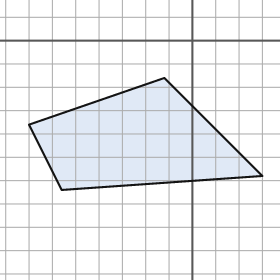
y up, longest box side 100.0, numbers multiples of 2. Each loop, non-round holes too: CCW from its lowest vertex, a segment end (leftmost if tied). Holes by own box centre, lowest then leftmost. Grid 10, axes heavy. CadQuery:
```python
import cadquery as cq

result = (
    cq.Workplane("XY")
    .moveTo(-56.0, -64.0)
    .lineTo(30.0, -58.0)
    .lineTo(-12.0, -16.0)
    .lineTo(-70.0, -36.0)
    .close()
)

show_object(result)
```